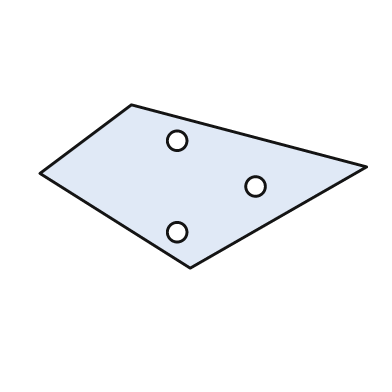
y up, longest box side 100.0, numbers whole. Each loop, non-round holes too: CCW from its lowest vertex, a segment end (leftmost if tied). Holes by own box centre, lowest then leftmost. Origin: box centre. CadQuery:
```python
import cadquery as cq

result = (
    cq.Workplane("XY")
    .moveTo(-4.0, -25.0)
    .lineTo(50.0, 6.0)
    .lineTo(-22.0, 25.0)
    .lineTo(-50.0, 4.0)
    .close()
    .moveTo(-8.0, -14.0)
    .circle(3.0)
    .moveTo(16.0, 0.0)
    .circle(3.0)
    .moveTo(-8.0, 14.0)
    .circle(3.0)
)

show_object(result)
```